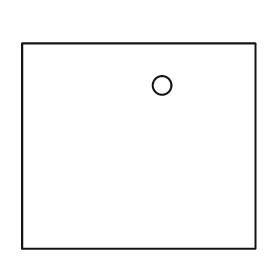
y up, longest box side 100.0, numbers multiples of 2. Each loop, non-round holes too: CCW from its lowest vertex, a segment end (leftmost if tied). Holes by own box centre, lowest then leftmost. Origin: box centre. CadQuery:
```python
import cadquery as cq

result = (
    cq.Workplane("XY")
    .moveTo(-50.0, -44.0)
    .lineTo(50.0, -44.0)
    .lineTo(50.0, 44.0)
    .lineTo(-50.0, 44.0)
    .close()
    .moveTo(10.0, 26.0)
    .circle(4.0)
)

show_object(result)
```